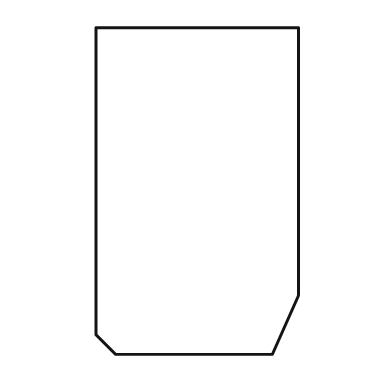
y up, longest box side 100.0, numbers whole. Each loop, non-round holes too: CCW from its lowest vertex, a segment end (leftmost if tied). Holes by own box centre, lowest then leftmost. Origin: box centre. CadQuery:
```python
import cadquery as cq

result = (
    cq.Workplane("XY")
    .moveTo(-25.0, -50.0)
    .lineTo(23.0, -50.0)
    .lineTo(31.0, -32.0)
    .lineTo(31.0, 50.0)
    .lineTo(-31.0, 50.0)
    .lineTo(-31.0, -44.0)
    .close()
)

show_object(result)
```